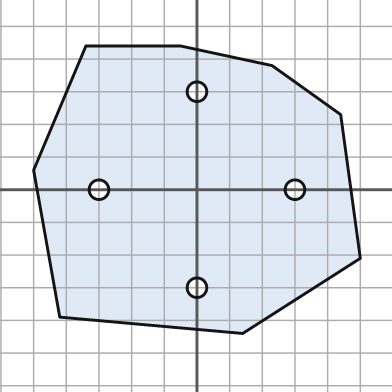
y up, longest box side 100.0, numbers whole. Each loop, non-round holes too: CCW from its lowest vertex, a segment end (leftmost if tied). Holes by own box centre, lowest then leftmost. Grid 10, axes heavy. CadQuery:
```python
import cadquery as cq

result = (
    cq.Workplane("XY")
    .moveTo(14.0, -44.0)
    .lineTo(50.0, -21.0)
    .lineTo(44.0, 23.0)
    .lineTo(23.0, 38.0)
    .lineTo(-5.0, 44.0)
    .lineTo(-34.0, 44.0)
    .lineTo(-50.0, 6.0)
    .lineTo(-42.0, -39.0)
    .close()
    .moveTo(0.0, -30.0)
    .circle(3.0)
    .moveTo(-30.0, 0.0)
    .circle(3.0)
    .moveTo(30.0, 0.0)
    .circle(3.0)
    .moveTo(0.0, 30.0)
    .circle(3.0)
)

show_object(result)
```